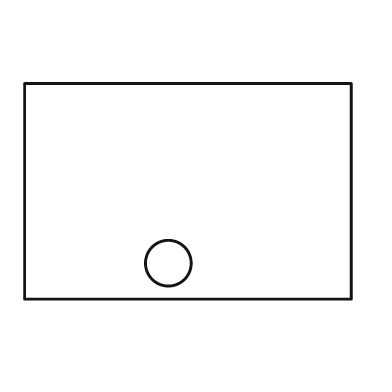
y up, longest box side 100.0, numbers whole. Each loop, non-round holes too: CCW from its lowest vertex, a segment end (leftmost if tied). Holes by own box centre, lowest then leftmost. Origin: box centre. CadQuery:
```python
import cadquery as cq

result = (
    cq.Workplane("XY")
    .moveTo(-50.0, -33.0)
    .lineTo(50.0, -33.0)
    .lineTo(50.0, 33.0)
    .lineTo(-50.0, 33.0)
    .close()
    .moveTo(-6.0, -22.0)
    .circle(7.0)
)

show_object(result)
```